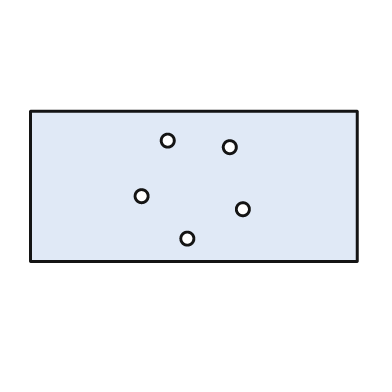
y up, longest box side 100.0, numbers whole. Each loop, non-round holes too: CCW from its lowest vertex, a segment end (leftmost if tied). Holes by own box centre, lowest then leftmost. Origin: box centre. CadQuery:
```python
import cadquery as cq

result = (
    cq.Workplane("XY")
    .moveTo(-50.0, -23.0)
    .lineTo(50.0, -23.0)
    .lineTo(50.0, 23.0)
    .lineTo(-50.0, 23.0)
    .close()
    .moveTo(-2.0, -16.0)
    .circle(2.0)
    .moveTo(15.0, -7.0)
    .circle(2.0)
    .moveTo(-16.0, -3.0)
    .circle(2.0)
    .moveTo(11.0, 12.0)
    .circle(2.0)
    .moveTo(-8.0, 14.0)
    .circle(2.0)
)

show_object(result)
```